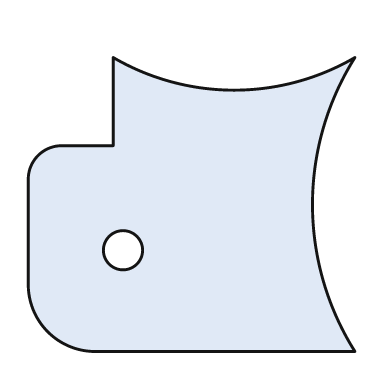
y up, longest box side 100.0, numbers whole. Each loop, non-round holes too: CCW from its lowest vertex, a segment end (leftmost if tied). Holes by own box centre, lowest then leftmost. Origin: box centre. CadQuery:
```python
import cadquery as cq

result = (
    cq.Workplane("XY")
    .moveTo(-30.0, -45.0)
    .lineTo(50.0, -45.0)
    .threePointArc((37.0, 0.0), (50.0, 45.0))
    .threePointArc((13.0, 35.0), (-24.0, 45.0))
    .lineTo(-24.0, 18.0)
    .lineTo(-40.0, 18.0)
    .threePointArc((-47.0, 15.0), (-50.0, 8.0))
    .lineTo(-50.0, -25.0)
    .threePointArc((-44.0, -39.0), (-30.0, -45.0))
    .close()
    .moveTo(-21.0, -14.0)
    .circle(6.0)
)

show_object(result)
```